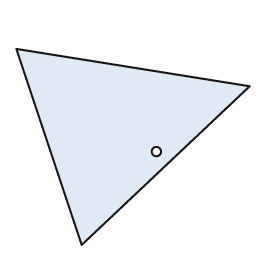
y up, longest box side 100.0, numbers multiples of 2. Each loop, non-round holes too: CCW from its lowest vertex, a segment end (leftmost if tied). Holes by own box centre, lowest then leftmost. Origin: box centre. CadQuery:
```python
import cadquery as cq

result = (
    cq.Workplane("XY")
    .moveTo(-22.0, -42.0)
    .lineTo(50.0, 26.0)
    .lineTo(-50.0, 42.0)
    .close()
    .moveTo(10.0, -2.0)
    .circle(2.0)
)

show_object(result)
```